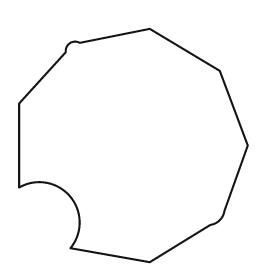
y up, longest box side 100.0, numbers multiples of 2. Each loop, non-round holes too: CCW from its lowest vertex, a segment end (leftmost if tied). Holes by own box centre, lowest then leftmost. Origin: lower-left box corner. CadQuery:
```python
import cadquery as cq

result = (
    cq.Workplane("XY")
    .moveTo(56.0, 0.0)
    .lineTo(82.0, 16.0)
    .threePointArc((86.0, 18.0), (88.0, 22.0))
    .lineTo(98.0, 50.0)
    .lineTo(86.0, 82.0)
    .lineTo(56.0, 100.0)
    .lineTo(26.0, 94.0)
    .threePointArc((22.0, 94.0), (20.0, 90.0))
    .lineTo(0.0, 68.0)
    .lineTo(0.0, 32.0)
    .threePointArc((22.0, 28.0), (22.0, 6.0))
    .close()
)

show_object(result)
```